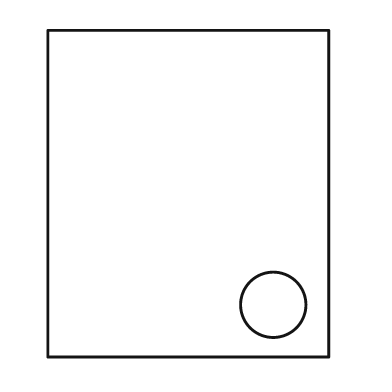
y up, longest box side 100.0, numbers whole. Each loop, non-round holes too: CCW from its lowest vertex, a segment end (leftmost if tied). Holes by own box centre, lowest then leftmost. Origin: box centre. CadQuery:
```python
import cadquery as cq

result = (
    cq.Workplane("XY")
    .moveTo(-43.0, -50.0)
    .lineTo(43.0, -50.0)
    .lineTo(43.0, 50.0)
    .lineTo(-43.0, 50.0)
    .close()
    .moveTo(26.0, -34.0)
    .circle(10.0)
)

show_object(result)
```